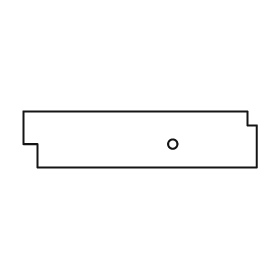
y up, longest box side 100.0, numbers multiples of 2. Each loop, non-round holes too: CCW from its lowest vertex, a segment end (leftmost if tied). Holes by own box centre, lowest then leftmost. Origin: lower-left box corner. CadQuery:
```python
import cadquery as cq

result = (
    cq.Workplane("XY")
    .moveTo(6.0, 0.0)
    .lineTo(100.0, 0.0)
    .lineTo(100.0, 18.0)
    .lineTo(96.0, 18.0)
    .lineTo(96.0, 24.0)
    .lineTo(0.0, 24.0)
    .lineTo(0.0, 10.0)
    .lineTo(6.0, 10.0)
    .close()
    .moveTo(64.0, 10.0)
    .circle(2.0)
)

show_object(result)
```